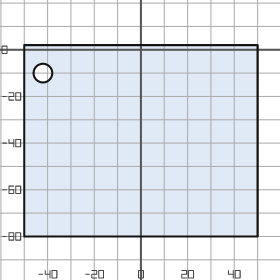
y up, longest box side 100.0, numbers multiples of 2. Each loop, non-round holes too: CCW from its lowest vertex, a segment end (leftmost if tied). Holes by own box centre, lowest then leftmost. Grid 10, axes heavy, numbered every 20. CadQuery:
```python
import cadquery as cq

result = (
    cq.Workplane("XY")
    .moveTo(-50.0, -80.0)
    .lineTo(50.0, -80.0)
    .lineTo(50.0, 2.0)
    .lineTo(-50.0, 2.0)
    .close()
    .moveTo(-42.0, -10.0)
    .circle(4.0)
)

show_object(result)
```